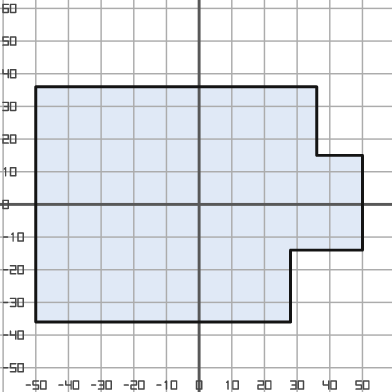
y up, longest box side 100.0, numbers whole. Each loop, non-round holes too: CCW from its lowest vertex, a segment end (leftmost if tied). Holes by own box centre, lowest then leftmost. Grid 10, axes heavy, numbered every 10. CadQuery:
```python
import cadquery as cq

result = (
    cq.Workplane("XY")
    .moveTo(-50.0, -36.0)
    .lineTo(28.0, -36.0)
    .lineTo(28.0, -14.0)
    .lineTo(50.0, -14.0)
    .lineTo(50.0, 15.0)
    .lineTo(36.0, 15.0)
    .lineTo(36.0, 36.0)
    .lineTo(-50.0, 36.0)
    .close()
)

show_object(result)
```